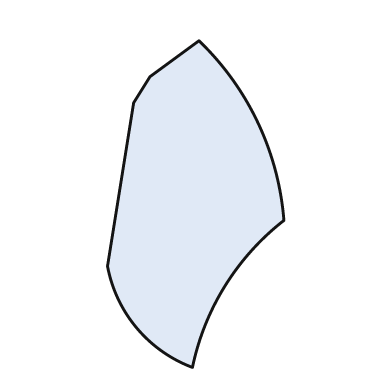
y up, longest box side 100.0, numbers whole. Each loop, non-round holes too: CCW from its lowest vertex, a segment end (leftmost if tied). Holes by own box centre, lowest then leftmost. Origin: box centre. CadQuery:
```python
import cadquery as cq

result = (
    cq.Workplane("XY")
    .moveTo(-1.0, -50.0)
    .threePointArc((9.0, -25.0), (27.0, -5.0))
    .threePointArc((19.0, 25.0), (1.0, 50.0))
    .lineTo(-14.0, 39.0)
    .lineTo(-19.0, 31.0)
    .lineTo(-27.0, -19.0)
    .threePointArc((-18.0, -38.0), (-1.0, -50.0))
    .close()
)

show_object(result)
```